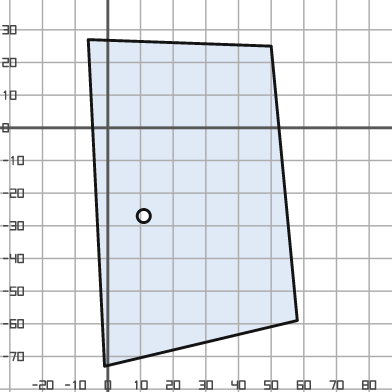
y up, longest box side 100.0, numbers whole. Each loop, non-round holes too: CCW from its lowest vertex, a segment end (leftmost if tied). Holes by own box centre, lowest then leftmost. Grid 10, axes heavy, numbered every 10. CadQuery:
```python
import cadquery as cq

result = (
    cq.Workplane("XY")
    .moveTo(-1.0, -73.0)
    .lineTo(58.0, -59.0)
    .lineTo(50.0, 25.0)
    .lineTo(-6.0, 27.0)
    .close()
    .moveTo(11.0, -27.0)
    .circle(2.0)
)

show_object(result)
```